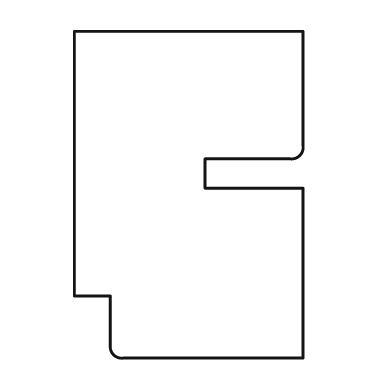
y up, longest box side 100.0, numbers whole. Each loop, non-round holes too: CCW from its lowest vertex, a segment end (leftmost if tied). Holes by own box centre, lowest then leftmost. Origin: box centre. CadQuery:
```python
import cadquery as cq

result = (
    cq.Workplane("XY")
    .moveTo(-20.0, -50.0)
    .lineTo(35.0, -50.0)
    .lineTo(35.0, 2.0)
    .lineTo(5.0, 2.0)
    .lineTo(5.0, 11.0)
    .lineTo(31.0, 11.0)
    .threePointArc((34.0, 12.0), (35.0, 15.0))
    .lineTo(35.0, 50.0)
    .lineTo(-35.0, 50.0)
    .lineTo(-35.0, -31.0)
    .lineTo(-24.0, -31.0)
    .lineTo(-24.0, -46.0)
    .threePointArc((-23.0, -49.0), (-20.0, -50.0))
    .close()
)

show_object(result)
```